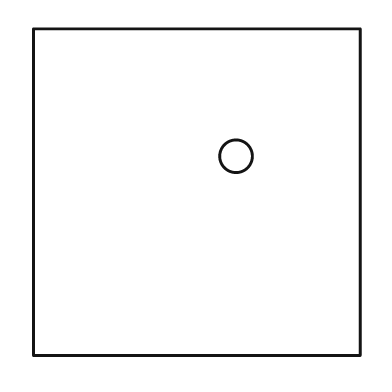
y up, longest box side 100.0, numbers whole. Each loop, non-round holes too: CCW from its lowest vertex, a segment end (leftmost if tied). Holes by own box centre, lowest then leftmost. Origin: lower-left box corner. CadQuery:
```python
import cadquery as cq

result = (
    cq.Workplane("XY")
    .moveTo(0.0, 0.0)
    .lineTo(100.0, 0.0)
    .lineTo(100.0, 100.0)
    .lineTo(0.0, 100.0)
    .close()
    .moveTo(62.0, 61.0)
    .circle(5.0)
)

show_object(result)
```